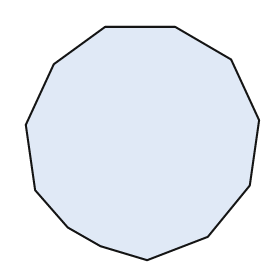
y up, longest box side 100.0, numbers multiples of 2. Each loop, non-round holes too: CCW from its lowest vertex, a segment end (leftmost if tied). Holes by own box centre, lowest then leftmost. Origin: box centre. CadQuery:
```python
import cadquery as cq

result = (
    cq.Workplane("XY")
    .moveTo(2.0, -50.0)
    .lineTo(28.0, -40.0)
    .lineTo(46.0, -18.0)
    .lineTo(50.0, 10.0)
    .lineTo(38.0, 36.0)
    .lineTo(14.0, 50.0)
    .lineTo(-16.0, 50.0)
    .lineTo(-38.0, 34.0)
    .lineTo(-50.0, 8.0)
    .lineTo(-46.0, -20.0)
    .lineTo(-32.0, -36.0)
    .lineTo(-18.0, -44.0)
    .close()
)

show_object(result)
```